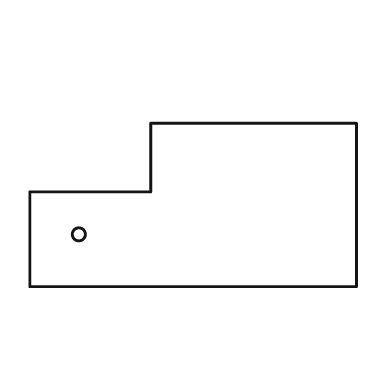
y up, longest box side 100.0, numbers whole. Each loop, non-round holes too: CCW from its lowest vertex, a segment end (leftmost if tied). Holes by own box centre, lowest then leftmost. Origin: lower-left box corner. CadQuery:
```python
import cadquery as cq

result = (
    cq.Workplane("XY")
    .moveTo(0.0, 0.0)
    .lineTo(100.0, 0.0)
    .lineTo(100.0, 50.0)
    .lineTo(37.0, 50.0)
    .lineTo(37.0, 29.0)
    .lineTo(0.0, 29.0)
    .close()
    .moveTo(15.0, 16.0)
    .circle(2.0)
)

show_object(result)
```